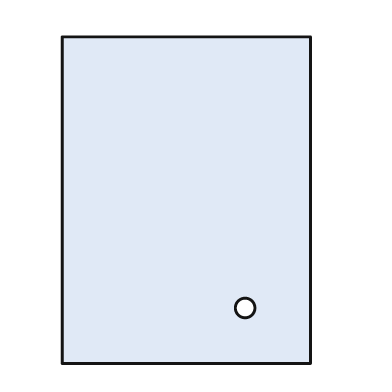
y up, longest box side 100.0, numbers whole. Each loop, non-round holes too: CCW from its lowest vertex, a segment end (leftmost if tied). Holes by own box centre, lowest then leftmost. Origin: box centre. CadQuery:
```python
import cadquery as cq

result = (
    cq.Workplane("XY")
    .moveTo(-38.0, -50.0)
    .lineTo(38.0, -50.0)
    .lineTo(38.0, 50.0)
    .lineTo(-38.0, 50.0)
    .close()
    .moveTo(18.0, -33.0)
    .circle(3.0)
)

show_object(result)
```